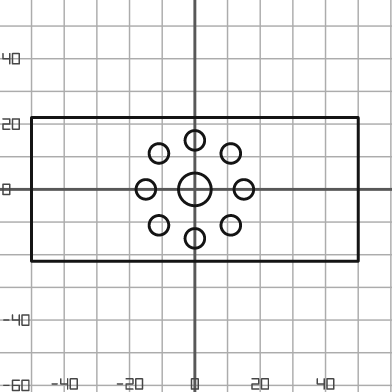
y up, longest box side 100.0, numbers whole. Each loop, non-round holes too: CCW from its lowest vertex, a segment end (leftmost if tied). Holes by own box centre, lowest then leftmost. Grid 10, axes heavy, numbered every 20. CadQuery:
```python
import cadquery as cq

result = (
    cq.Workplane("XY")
    .moveTo(-50.0, -22.0)
    .lineTo(50.0, -22.0)
    .lineTo(50.0, 22.0)
    .lineTo(-50.0, 22.0)
    .close()
    .moveTo(0.0, -15.0)
    .circle(3.0)
    .moveTo(-11.0, -11.0)
    .circle(3.0)
    .moveTo(11.0, -11.0)
    .circle(3.0)
    .moveTo(-15.0, 0.0)
    .circle(3.0)
    .moveTo(0.0, 0.0)
    .circle(5.0)
    .moveTo(15.0, 0.0)
    .circle(3.0)
    .moveTo(-11.0, 11.0)
    .circle(3.0)
    .moveTo(11.0, 11.0)
    .circle(3.0)
    .moveTo(0.0, 15.0)
    .circle(3.0)
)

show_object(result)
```